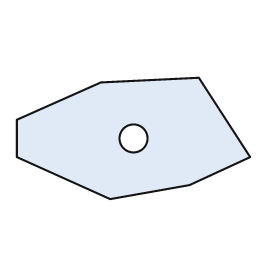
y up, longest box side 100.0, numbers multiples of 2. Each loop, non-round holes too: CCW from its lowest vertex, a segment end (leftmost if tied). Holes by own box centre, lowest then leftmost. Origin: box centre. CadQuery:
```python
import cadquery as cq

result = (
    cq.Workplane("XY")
    .moveTo(-10.0, -26.0)
    .lineTo(24.0, -20.0)
    .lineTo(50.0, -8.0)
    .lineTo(28.0, 26.0)
    .lineTo(-14.0, 24.0)
    .lineTo(-50.0, 8.0)
    .lineTo(-50.0, -8.0)
    .close()
    .moveTo(0.0, 0.0)
    .circle(6.0)
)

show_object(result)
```